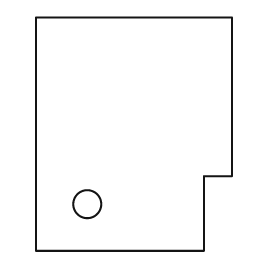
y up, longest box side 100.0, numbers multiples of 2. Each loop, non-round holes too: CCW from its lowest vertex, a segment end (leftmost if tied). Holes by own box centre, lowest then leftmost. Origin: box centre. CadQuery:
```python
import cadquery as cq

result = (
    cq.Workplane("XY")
    .moveTo(-42.0, -50.0)
    .lineTo(30.0, -50.0)
    .lineTo(30.0, -18.0)
    .lineTo(42.0, -18.0)
    .lineTo(42.0, 50.0)
    .lineTo(-42.0, 50.0)
    .close()
    .moveTo(-20.0, -30.0)
    .circle(6.0)
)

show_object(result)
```